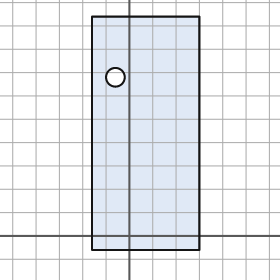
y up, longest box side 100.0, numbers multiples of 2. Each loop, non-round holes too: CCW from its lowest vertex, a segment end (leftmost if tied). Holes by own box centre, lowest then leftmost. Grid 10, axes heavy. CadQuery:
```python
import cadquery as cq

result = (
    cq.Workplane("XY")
    .moveTo(-16.0, -6.0)
    .lineTo(30.0, -6.0)
    .lineTo(30.0, 94.0)
    .lineTo(-16.0, 94.0)
    .close()
    .moveTo(-6.0, 68.0)
    .circle(4.0)
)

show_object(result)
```